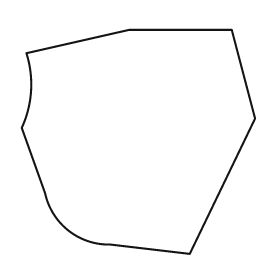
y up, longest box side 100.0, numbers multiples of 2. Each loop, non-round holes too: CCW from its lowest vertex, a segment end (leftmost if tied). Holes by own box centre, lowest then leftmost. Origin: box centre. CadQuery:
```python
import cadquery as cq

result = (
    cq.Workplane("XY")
    .moveTo(22.0, -48.0)
    .lineTo(50.0, 10.0)
    .lineTo(40.0, 48.0)
    .lineTo(-4.0, 48.0)
    .lineTo(-48.0, 38.0)
    .threePointArc((-46.0, 22.0), (-50.0, 6.0))
    .lineTo(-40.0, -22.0)
    .threePointArc((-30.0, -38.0), (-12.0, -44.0))
    .close()
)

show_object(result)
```